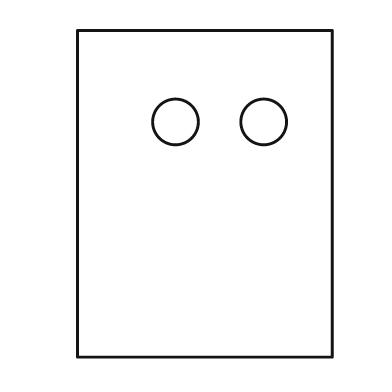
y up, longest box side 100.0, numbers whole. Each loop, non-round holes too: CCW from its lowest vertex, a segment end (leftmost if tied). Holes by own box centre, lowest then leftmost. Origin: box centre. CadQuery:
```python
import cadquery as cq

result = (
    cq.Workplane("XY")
    .moveTo(-39.0, -50.0)
    .lineTo(39.0, -50.0)
    .lineTo(39.0, 50.0)
    .lineTo(-39.0, 50.0)
    .close()
    .moveTo(-9.0, 22.0)
    .circle(7.0)
    .moveTo(18.0, 22.0)
    .circle(7.0)
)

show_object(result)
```